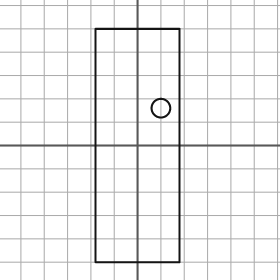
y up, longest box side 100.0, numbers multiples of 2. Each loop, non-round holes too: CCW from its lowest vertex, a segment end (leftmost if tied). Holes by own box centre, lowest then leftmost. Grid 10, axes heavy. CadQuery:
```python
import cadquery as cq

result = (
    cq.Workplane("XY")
    .moveTo(-18.0, -50.0)
    .lineTo(18.0, -50.0)
    .lineTo(18.0, 50.0)
    .lineTo(-18.0, 50.0)
    .close()
    .moveTo(10.0, 16.0)
    .circle(4.0)
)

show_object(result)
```